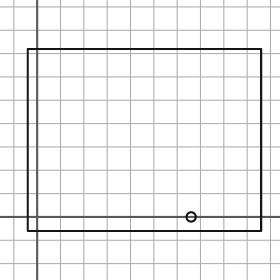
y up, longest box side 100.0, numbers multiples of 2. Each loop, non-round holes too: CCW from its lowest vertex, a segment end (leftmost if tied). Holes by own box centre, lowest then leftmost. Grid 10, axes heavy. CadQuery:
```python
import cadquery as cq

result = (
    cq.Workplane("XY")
    .moveTo(-4.0, -6.0)
    .lineTo(96.0, -6.0)
    .lineTo(96.0, 72.0)
    .lineTo(-4.0, 72.0)
    .close()
    .moveTo(66.0, 0.0)
    .circle(2.0)
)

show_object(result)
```